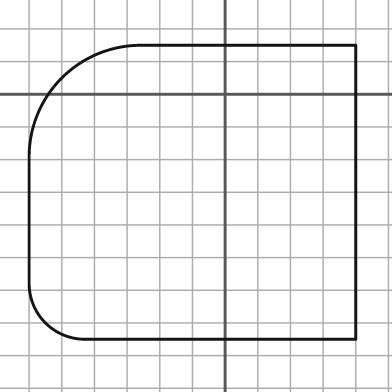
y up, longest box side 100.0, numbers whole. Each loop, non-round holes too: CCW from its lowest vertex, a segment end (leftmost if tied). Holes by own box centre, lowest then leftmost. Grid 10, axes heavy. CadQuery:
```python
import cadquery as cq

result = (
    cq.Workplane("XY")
    .moveTo(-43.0, -75.0)
    .lineTo(40.0, -75.0)
    .lineTo(40.0, 15.0)
    .lineTo(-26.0, 15.0)
    .threePointArc((-50.0, 5.0), (-60.0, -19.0))
    .lineTo(-60.0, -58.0)
    .threePointArc((-55.0, -70.0), (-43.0, -75.0))
    .close()
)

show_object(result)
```